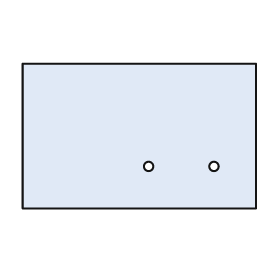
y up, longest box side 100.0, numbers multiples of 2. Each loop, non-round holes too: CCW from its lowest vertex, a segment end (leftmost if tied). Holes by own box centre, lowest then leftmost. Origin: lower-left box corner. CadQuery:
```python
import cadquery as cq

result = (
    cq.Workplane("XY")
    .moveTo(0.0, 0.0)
    .lineTo(100.0, 0.0)
    .lineTo(100.0, 62.0)
    .lineTo(0.0, 62.0)
    .close()
    .moveTo(54.0, 18.0)
    .circle(2.0)
    .moveTo(82.0, 18.0)
    .circle(2.0)
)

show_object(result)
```